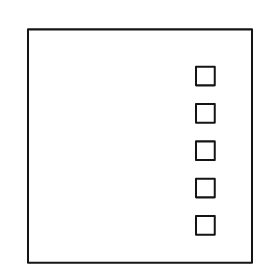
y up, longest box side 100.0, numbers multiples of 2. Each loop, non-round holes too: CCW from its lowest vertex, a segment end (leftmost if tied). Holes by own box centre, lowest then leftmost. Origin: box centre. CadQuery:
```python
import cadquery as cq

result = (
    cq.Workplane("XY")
    .moveTo(-48.0, -50.0)
    .lineTo(48.0, -50.0)
    .lineTo(48.0, 50.0)
    .lineTo(-48.0, 50.0)
    .close()
    .moveTo(24.0, -38.0)
    .lineTo(32.0, -38.0)
    .lineTo(32.0, -30.0)
    .lineTo(24.0, -30.0)
    .close()
    .moveTo(24.0, -22.0)
    .lineTo(32.0, -22.0)
    .lineTo(32.0, -14.0)
    .lineTo(24.0, -14.0)
    .close()
    .moveTo(24.0, -6.0)
    .lineTo(32.0, -6.0)
    .lineTo(32.0, 2.0)
    .lineTo(24.0, 2.0)
    .close()
    .moveTo(24.0, 10.0)
    .lineTo(32.0, 10.0)
    .lineTo(32.0, 18.0)
    .lineTo(24.0, 18.0)
    .close()
    .moveTo(24.0, 26.0)
    .lineTo(32.0, 26.0)
    .lineTo(32.0, 34.0)
    .lineTo(24.0, 34.0)
    .close()
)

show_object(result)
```